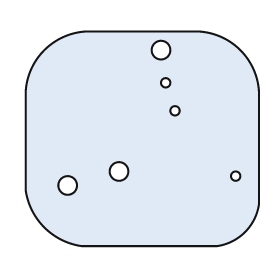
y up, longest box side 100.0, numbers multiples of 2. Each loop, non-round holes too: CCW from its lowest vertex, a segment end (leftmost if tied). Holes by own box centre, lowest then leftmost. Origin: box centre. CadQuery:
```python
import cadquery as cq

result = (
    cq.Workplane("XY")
    .moveTo(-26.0, -46.0)
    .lineTo(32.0, -46.0)
    .threePointArc((44.0, -40.0), (50.0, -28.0))
    .lineTo(50.0, 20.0)
    .threePointArc((42.0, 38.0), (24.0, 46.0))
    .lineTo(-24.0, 46.0)
    .threePointArc((-42.0, 38.0), (-50.0, 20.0))
    .lineTo(-50.0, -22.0)
    .threePointArc((-42.0, -38.0), (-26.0, -46.0))
    .close()
    .moveTo(-32.0, -20.0)
    .circle(4.0)
    .moveTo(40.0, -16.0)
    .circle(2.0)
    .moveTo(-10.0, -14.0)
    .circle(4.0)
    .moveTo(14.0, 12.0)
    .circle(2.0)
    .moveTo(10.0, 24.0)
    .circle(2.0)
    .moveTo(8.0, 38.0)
    .circle(4.0)
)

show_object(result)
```